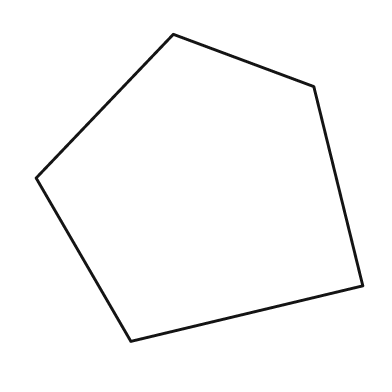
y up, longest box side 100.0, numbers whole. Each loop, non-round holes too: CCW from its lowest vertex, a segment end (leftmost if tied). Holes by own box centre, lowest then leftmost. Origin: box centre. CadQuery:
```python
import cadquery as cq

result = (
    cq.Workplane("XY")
    .moveTo(-21.0, -47.0)
    .lineTo(50.0, -30.0)
    .lineTo(35.0, 31.0)
    .lineTo(-8.0, 47.0)
    .lineTo(-50.0, 3.0)
    .close()
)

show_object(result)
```